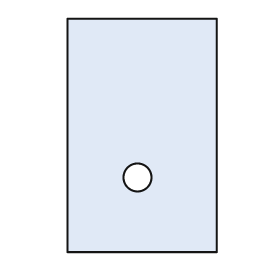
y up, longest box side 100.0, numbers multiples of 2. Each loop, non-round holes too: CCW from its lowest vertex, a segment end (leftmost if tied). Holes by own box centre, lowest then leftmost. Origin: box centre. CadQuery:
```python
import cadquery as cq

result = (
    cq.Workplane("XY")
    .moveTo(-32.0, -50.0)
    .lineTo(32.0, -50.0)
    .lineTo(32.0, 50.0)
    .lineTo(-32.0, 50.0)
    .close()
    .moveTo(-2.0, -18.0)
    .circle(6.0)
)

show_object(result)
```